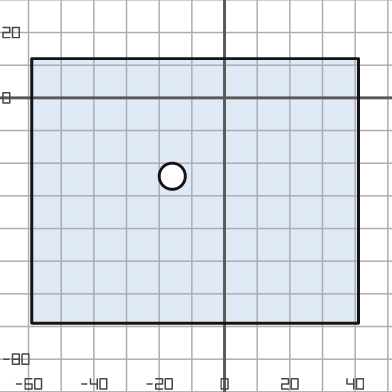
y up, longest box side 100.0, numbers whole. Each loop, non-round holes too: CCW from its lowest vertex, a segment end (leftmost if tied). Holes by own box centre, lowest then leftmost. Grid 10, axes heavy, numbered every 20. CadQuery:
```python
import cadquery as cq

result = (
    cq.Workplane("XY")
    .moveTo(-59.0, -69.0)
    .lineTo(41.0, -69.0)
    .lineTo(41.0, 12.0)
    .lineTo(-59.0, 12.0)
    .close()
    .moveTo(-16.0, -24.0)
    .circle(4.0)
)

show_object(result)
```